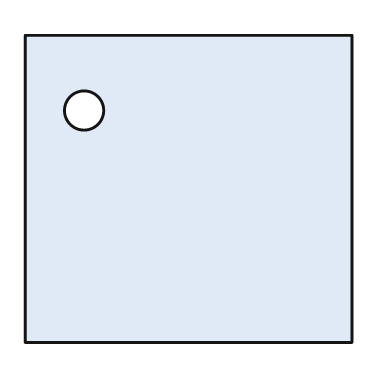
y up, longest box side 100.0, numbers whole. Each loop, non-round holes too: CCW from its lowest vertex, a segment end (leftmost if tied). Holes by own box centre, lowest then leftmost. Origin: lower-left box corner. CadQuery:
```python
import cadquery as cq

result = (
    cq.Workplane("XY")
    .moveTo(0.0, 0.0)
    .lineTo(100.0, 0.0)
    .lineTo(100.0, 94.0)
    .lineTo(0.0, 94.0)
    .close()
    .moveTo(18.0, 71.0)
    .circle(6.0)
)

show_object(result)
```